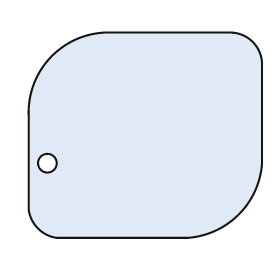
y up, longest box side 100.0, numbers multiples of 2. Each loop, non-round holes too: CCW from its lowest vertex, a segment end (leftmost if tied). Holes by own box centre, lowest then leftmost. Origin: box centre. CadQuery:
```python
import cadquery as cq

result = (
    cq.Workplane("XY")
    .moveTo(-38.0, -44.0)
    .lineTo(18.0, -44.0)
    .threePointArc((40.0, -34.0), (50.0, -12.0))
    .lineTo(50.0, 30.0)
    .threePointArc((46.0, 40.0), (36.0, 44.0))
    .lineTo(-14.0, 44.0)
    .threePointArc((-40.0, 34.0), (-50.0, 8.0))
    .lineTo(-50.0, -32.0)
    .threePointArc((-46.0, -40.0), (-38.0, -44.0))
    .close()
    .moveTo(-42.0, -12.0)
    .circle(4.0)
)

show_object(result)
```